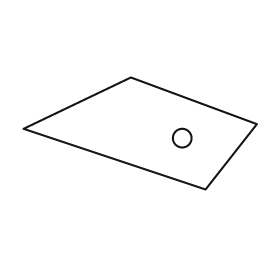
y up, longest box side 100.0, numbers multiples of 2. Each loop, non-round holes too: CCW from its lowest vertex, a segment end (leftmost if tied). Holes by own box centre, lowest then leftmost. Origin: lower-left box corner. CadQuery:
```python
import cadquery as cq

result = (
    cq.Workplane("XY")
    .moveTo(78.0, 0.0)
    .lineTo(100.0, 28.0)
    .lineTo(46.0, 48.0)
    .lineTo(0.0, 26.0)
    .close()
    .moveTo(68.0, 22.0)
    .circle(4.0)
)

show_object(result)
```